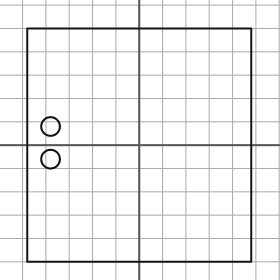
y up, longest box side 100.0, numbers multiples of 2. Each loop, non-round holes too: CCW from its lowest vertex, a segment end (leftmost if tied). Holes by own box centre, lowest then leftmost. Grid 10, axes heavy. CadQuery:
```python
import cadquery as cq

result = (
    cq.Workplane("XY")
    .moveTo(-48.0, -50.0)
    .lineTo(48.0, -50.0)
    .lineTo(48.0, 50.0)
    .lineTo(-48.0, 50.0)
    .close()
    .moveTo(-38.0, -6.0)
    .circle(4.0)
    .moveTo(-38.0, 8.0)
    .circle(4.0)
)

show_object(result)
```